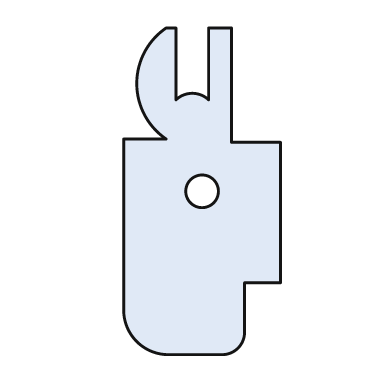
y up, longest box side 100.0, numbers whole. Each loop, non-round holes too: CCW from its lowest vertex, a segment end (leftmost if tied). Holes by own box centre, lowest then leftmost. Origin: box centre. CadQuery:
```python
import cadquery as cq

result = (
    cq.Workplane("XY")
    .moveTo(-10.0, -50.0)
    .lineTo(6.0, -50.0)
    .threePointArc((11.0, -48.0), (13.0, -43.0))
    .lineTo(13.0, -28.0)
    .lineTo(24.0, -28.0)
    .lineTo(24.0, 15.0)
    .lineTo(9.0, 15.0)
    .lineTo(9.0, 50.0)
    .lineTo(2.0, 50.0)
    .lineTo(2.0, 28.0)
    .threePointArc((-3.0, 30.0), (-8.0, 28.0))
    .lineTo(-8.0, 50.0)
    .lineTo(-11.0, 50.0)
    .threePointArc((-20.0, 33.0), (-11.0, 16.0))
    .lineTo(-24.0, 16.0)
    .lineTo(-24.0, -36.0)
    .threePointArc((-20.0, -46.0), (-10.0, -50.0))
    .close()
    .moveTo(0.0, 0.0)
    .circle(5.0)
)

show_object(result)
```